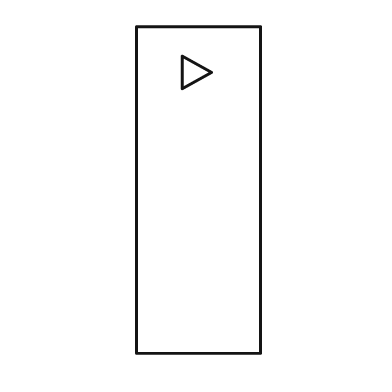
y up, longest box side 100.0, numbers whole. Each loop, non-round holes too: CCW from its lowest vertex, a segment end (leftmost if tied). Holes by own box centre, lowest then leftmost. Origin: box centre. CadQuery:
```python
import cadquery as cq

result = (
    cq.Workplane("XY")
    .moveTo(-19.0, -50.0)
    .lineTo(19.0, -50.0)
    .lineTo(19.0, 50.0)
    .lineTo(-19.0, 50.0)
    .close()
    .moveTo(-5.0, 31.0)
    .lineTo(4.0, 36.0)
    .lineTo(-5.0, 41.0)
    .close()
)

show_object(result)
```